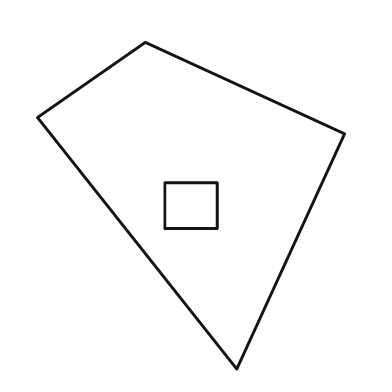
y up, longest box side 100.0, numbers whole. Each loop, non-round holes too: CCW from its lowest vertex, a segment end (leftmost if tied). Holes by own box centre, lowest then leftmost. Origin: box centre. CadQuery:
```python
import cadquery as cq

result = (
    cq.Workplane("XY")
    .moveTo(14.0, -50.0)
    .lineTo(47.0, 22.0)
    .lineTo(-14.0, 50.0)
    .lineTo(-47.0, 27.0)
    .close()
    .moveTo(-8.0, -7.0)
    .lineTo(8.0, -7.0)
    .lineTo(8.0, 7.0)
    .lineTo(-8.0, 7.0)
    .close()
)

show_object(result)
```